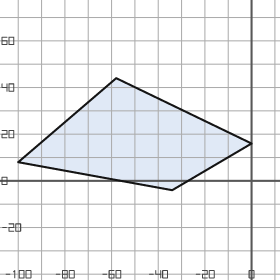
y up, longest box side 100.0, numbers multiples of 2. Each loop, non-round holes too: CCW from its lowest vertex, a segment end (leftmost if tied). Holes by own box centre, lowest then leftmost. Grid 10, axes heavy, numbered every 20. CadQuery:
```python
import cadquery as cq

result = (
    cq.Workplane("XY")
    .moveTo(-34.0, -4.0)
    .lineTo(0.0, 16.0)
    .lineTo(-58.0, 44.0)
    .lineTo(-100.0, 8.0)
    .close()
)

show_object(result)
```